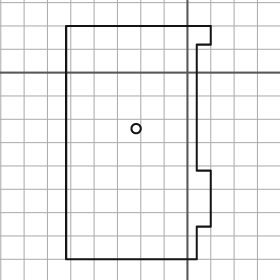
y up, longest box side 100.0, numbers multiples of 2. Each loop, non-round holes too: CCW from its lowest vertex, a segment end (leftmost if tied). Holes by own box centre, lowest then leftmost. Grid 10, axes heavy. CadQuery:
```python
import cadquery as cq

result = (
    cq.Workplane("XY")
    .moveTo(-52.0, -80.0)
    .lineTo(4.0, -80.0)
    .lineTo(4.0, -66.0)
    .lineTo(10.0, -66.0)
    .lineTo(10.0, -42.0)
    .lineTo(4.0, -42.0)
    .lineTo(4.0, 12.0)
    .lineTo(10.0, 12.0)
    .lineTo(10.0, 20.0)
    .lineTo(-52.0, 20.0)
    .close()
    .moveTo(-22.0, -24.0)
    .circle(2.0)
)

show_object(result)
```